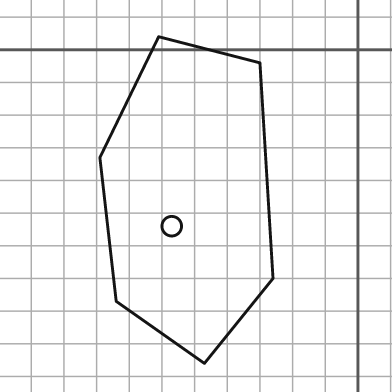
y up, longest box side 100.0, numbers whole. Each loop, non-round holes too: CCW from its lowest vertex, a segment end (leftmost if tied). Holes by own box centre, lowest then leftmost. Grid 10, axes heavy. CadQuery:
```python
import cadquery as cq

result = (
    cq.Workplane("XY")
    .moveTo(-47.0, -96.0)
    .lineTo(-26.0, -70.0)
    .lineTo(-30.0, -4.0)
    .lineTo(-61.0, 4.0)
    .lineTo(-79.0, -33.0)
    .lineTo(-74.0, -77.0)
    .close()
    .moveTo(-57.0, -54.0)
    .circle(3.0)
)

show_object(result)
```